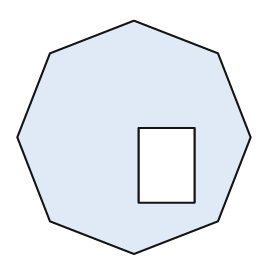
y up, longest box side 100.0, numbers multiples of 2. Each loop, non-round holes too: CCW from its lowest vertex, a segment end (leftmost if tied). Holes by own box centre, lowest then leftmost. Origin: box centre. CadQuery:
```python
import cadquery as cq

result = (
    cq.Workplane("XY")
    .moveTo(0.0, -50.0)
    .lineTo(36.0, -36.0)
    .lineTo(50.0, 0.0)
    .lineTo(36.0, 36.0)
    .lineTo(0.0, 50.0)
    .lineTo(-36.0, 36.0)
    .lineTo(-50.0, 0.0)
    .lineTo(-36.0, -36.0)
    .close()
    .moveTo(2.0, -28.0)
    .lineTo(26.0, -28.0)
    .lineTo(26.0, 4.0)
    .lineTo(2.0, 4.0)
    .close()
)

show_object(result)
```